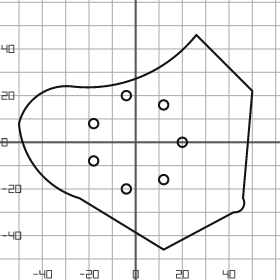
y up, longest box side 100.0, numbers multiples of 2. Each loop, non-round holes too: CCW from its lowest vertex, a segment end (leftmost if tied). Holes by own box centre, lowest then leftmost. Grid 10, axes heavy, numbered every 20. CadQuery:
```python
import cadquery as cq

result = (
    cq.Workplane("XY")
    .moveTo(12.0, -46.0)
    .lineTo(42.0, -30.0)
    .threePointArc((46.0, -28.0), (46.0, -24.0))
    .lineTo(50.0, 22.0)
    .lineTo(26.0, 46.0)
    .threePointArc((2.0, 28.0), (-28.0, 24.0))
    .threePointArc((-42.0, 20.0), (-50.0, 8.0))
    .threePointArc((-42.0, -12.0), (-24.0, -24.0))
    .close()
    .moveTo(-4.0, -20.0)
    .circle(2.0)
    .moveTo(12.0, -16.0)
    .circle(2.0)
    .moveTo(-18.0, -8.0)
    .circle(2.0)
    .moveTo(20.0, 0.0)
    .circle(2.0)
    .moveTo(-18.0, 8.0)
    .circle(2.0)
    .moveTo(12.0, 16.0)
    .circle(2.0)
    .moveTo(-4.0, 20.0)
    .circle(2.0)
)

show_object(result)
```